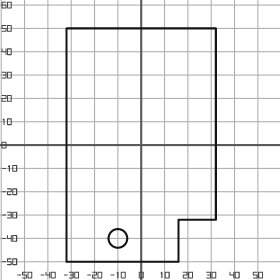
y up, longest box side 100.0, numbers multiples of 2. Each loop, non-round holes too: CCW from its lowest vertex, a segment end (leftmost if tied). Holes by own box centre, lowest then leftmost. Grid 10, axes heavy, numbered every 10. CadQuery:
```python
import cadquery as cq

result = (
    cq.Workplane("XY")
    .moveTo(-32.0, -50.0)
    .lineTo(16.0, -50.0)
    .lineTo(16.0, -32.0)
    .lineTo(32.0, -32.0)
    .lineTo(32.0, 50.0)
    .lineTo(-32.0, 50.0)
    .close()
    .moveTo(-10.0, -40.0)
    .circle(4.0)
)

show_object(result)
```